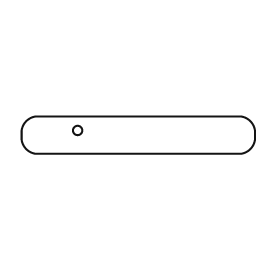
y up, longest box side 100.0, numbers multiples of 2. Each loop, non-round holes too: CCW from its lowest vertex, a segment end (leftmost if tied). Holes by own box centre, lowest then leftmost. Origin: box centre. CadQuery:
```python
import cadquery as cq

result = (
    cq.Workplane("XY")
    .moveTo(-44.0, -8.0)
    .lineTo(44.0, -8.0)
    .threePointArc((48.0, -6.0), (50.0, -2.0))
    .lineTo(50.0, 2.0)
    .threePointArc((48.0, 6.0), (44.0, 8.0))
    .lineTo(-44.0, 8.0)
    .threePointArc((-48.0, 6.0), (-50.0, 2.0))
    .lineTo(-50.0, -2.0)
    .threePointArc((-48.0, -6.0), (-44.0, -8.0))
    .close()
    .moveTo(-26.0, 2.0)
    .circle(2.0)
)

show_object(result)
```